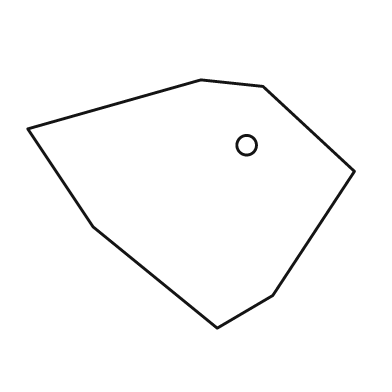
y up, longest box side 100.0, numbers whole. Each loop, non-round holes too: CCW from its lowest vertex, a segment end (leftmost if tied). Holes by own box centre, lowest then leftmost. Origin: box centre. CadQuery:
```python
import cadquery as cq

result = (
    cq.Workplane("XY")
    .moveTo(8.0, -38.0)
    .lineTo(25.0, -28.0)
    .lineTo(50.0, 10.0)
    .lineTo(22.0, 36.0)
    .lineTo(3.0, 38.0)
    .lineTo(-50.0, 23.0)
    .lineTo(-30.0, -7.0)
    .close()
    .moveTo(17.0, 18.0)
    .circle(3.0)
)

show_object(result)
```